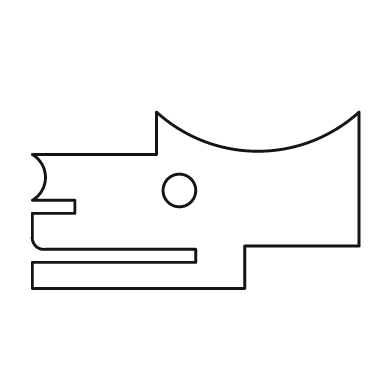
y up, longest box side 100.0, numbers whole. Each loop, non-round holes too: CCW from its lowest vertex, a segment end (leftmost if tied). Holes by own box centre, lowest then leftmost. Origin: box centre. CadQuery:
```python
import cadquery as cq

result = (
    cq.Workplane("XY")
    .moveTo(-50.0, -27.0)
    .lineTo(15.0, -27.0)
    .lineTo(15.0, -14.0)
    .lineTo(50.0, -14.0)
    .lineTo(50.0, 27.0)
    .threePointArc((19.0, 15.0), (-12.0, 27.0))
    .lineTo(-12.0, 14.0)
    .lineTo(-50.0, 14.0)
    .threePointArc((-46.0, 7.0), (-50.0, 0.0))
    .lineTo(-37.0, 0.0)
    .lineTo(-37.0, -4.0)
    .lineTo(-50.0, -4.0)
    .lineTo(-50.0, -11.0)
    .threePointArc((-49.0, -14.0), (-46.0, -15.0))
    .lineTo(0.0, -15.0)
    .lineTo(0.0, -19.0)
    .lineTo(-50.0, -19.0)
    .close()
    .moveTo(-5.0, 3.0)
    .circle(5.0)
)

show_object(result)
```